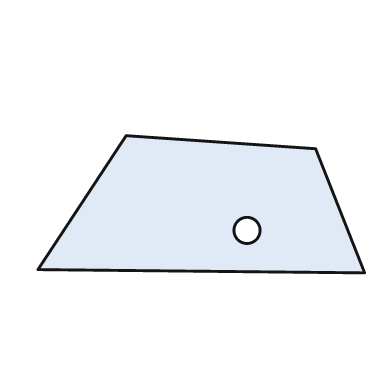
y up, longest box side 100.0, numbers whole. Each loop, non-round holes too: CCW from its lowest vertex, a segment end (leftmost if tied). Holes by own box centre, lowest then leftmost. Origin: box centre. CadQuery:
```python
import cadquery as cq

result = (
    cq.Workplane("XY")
    .moveTo(50.0, -21.0)
    .lineTo(35.0, 17.0)
    .lineTo(-23.0, 21.0)
    .lineTo(-50.0, -20.0)
    .close()
    .moveTo(14.0, -8.0)
    .circle(4.0)
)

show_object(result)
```